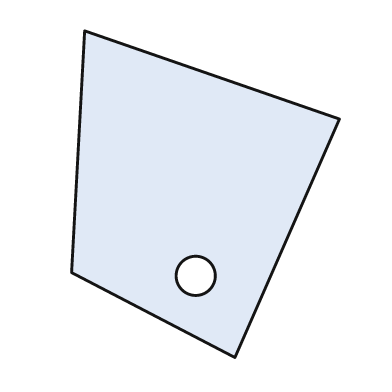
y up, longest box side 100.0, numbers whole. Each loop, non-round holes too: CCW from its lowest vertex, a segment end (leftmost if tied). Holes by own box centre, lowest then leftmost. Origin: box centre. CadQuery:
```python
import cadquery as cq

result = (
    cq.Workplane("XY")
    .moveTo(9.0, -50.0)
    .lineTo(41.0, 23.0)
    .lineTo(-37.0, 50.0)
    .lineTo(-41.0, -24.0)
    .close()
    .moveTo(-3.0, -25.0)
    .circle(6.0)
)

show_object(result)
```